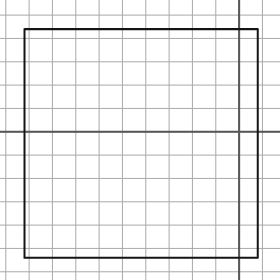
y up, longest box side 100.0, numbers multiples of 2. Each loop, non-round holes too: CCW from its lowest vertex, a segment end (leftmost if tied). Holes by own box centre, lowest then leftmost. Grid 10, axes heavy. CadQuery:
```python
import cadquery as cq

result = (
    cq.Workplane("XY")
    .moveTo(-92.0, -54.0)
    .lineTo(8.0, -54.0)
    .lineTo(8.0, 44.0)
    .lineTo(-92.0, 44.0)
    .close()
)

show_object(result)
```